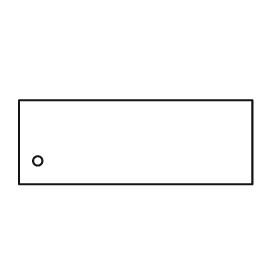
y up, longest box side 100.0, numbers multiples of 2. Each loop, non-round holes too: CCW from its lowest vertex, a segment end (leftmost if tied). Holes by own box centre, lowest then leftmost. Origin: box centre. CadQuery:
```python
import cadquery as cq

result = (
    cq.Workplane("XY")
    .moveTo(-50.0, -18.0)
    .lineTo(50.0, -18.0)
    .lineTo(50.0, 18.0)
    .lineTo(-50.0, 18.0)
    .close()
    .moveTo(-42.0, -8.0)
    .circle(2.0)
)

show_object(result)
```